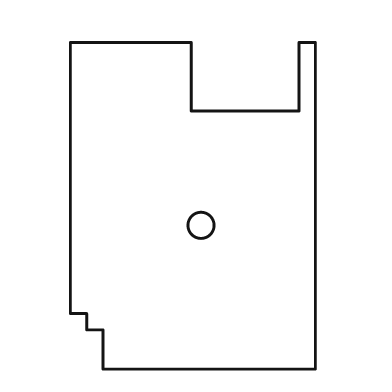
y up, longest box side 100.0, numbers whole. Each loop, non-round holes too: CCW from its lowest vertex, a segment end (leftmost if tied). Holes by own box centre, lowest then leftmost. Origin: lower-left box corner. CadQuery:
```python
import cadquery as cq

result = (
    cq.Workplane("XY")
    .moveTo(10.0, 0.0)
    .lineTo(75.0, 0.0)
    .lineTo(75.0, 100.0)
    .lineTo(70.0, 100.0)
    .lineTo(70.0, 79.0)
    .lineTo(37.0, 79.0)
    .lineTo(37.0, 100.0)
    .lineTo(0.0, 100.0)
    .lineTo(0.0, 17.0)
    .lineTo(5.0, 17.0)
    .lineTo(5.0, 12.0)
    .lineTo(10.0, 12.0)
    .close()
    .moveTo(40.0, 44.0)
    .circle(4.0)
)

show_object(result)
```